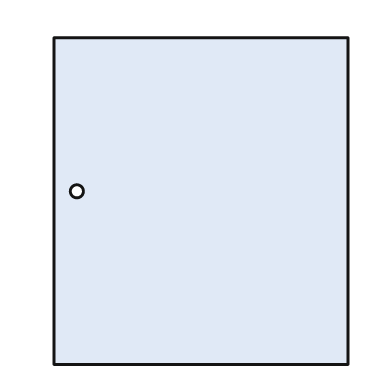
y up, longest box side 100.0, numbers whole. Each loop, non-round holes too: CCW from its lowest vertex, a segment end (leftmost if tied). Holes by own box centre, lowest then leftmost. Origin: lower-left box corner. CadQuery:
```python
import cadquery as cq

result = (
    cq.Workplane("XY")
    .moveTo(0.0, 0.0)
    .lineTo(90.0, 0.0)
    .lineTo(90.0, 100.0)
    .lineTo(0.0, 100.0)
    .close()
    .moveTo(7.0, 53.0)
    .circle(2.0)
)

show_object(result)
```